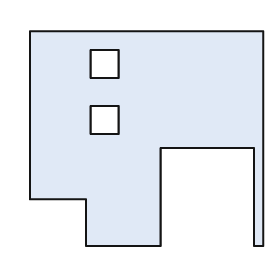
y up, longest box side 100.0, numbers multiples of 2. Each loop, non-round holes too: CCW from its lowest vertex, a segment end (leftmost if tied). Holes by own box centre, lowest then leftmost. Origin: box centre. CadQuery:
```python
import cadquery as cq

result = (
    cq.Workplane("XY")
    .moveTo(-26.0, -46.0)
    .lineTo(6.0, -46.0)
    .lineTo(6.0, -4.0)
    .lineTo(46.0, -4.0)
    .lineTo(46.0, -46.0)
    .lineTo(50.0, -46.0)
    .lineTo(50.0, 46.0)
    .lineTo(-50.0, 46.0)
    .lineTo(-50.0, -26.0)
    .lineTo(-26.0, -26.0)
    .close()
    .moveTo(-24.0, 2.0)
    .lineTo(-12.0, 2.0)
    .lineTo(-12.0, 14.0)
    .lineTo(-24.0, 14.0)
    .close()
    .moveTo(-24.0, 26.0)
    .lineTo(-12.0, 26.0)
    .lineTo(-12.0, 38.0)
    .lineTo(-24.0, 38.0)
    .close()
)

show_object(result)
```